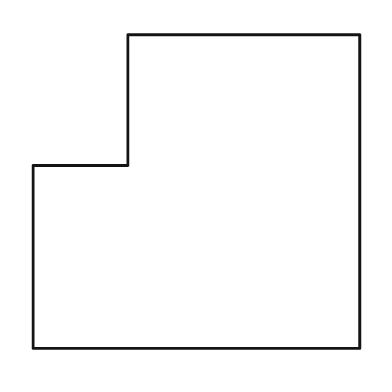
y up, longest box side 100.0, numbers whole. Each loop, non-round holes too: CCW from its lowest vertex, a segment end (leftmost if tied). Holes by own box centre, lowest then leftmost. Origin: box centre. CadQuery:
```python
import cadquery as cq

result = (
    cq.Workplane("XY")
    .moveTo(-50.0, -48.0)
    .lineTo(50.0, -48.0)
    .lineTo(50.0, 48.0)
    .lineTo(-21.0, 48.0)
    .lineTo(-21.0, 8.0)
    .lineTo(-50.0, 8.0)
    .close()
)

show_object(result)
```